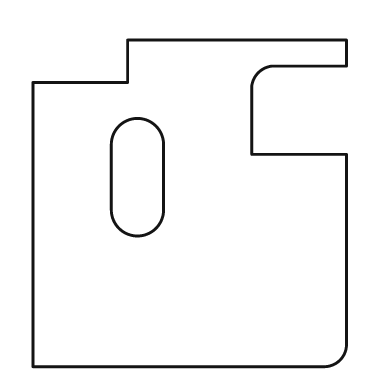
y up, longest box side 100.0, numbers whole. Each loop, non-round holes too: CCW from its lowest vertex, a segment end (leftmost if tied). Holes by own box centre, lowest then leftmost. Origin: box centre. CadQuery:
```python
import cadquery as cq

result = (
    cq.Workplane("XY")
    .moveTo(-48.0, -50.0)
    .lineTo(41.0, -50.0)
    .threePointArc((46.0, -48.0), (48.0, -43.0))
    .lineTo(48.0, 15.0)
    .lineTo(19.0, 15.0)
    .lineTo(19.0, 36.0)
    .threePointArc((21.0, 40.0), (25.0, 42.0))
    .lineTo(48.0, 42.0)
    .lineTo(48.0, 50.0)
    .lineTo(-19.0, 50.0)
    .lineTo(-19.0, 37.0)
    .lineTo(-48.0, 37.0)
    .close()
    .moveTo(-24.0, -2.0)
    .threePointArc((-16.0, -10.0), (-8.0, -2.0))
    .lineTo(-8.0, 18.0)
    .threePointArc((-16.0, 26.0), (-24.0, 18.0))
    .close()
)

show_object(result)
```